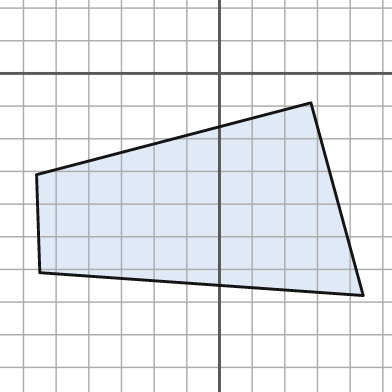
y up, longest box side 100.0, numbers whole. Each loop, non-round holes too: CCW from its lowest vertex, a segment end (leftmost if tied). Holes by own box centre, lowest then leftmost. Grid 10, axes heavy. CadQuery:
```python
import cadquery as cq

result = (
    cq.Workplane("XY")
    .moveTo(44.0, -68.0)
    .lineTo(28.0, -9.0)
    .lineTo(-56.0, -31.0)
    .lineTo(-55.0, -61.0)
    .close()
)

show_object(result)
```